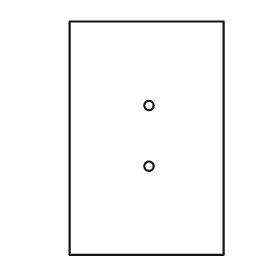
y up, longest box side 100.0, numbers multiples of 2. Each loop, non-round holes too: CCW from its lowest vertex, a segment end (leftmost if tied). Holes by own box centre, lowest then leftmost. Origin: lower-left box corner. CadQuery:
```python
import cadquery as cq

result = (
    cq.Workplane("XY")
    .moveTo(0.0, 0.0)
    .lineTo(66.0, 0.0)
    .lineTo(66.0, 100.0)
    .lineTo(0.0, 100.0)
    .close()
    .moveTo(34.0, 38.0)
    .circle(2.0)
    .moveTo(34.0, 64.0)
    .circle(2.0)
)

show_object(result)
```